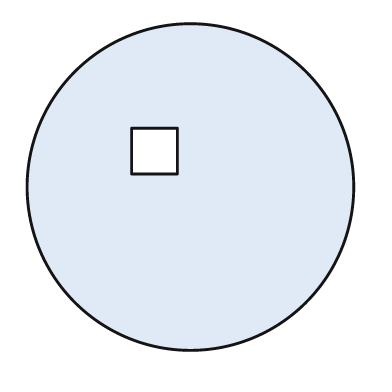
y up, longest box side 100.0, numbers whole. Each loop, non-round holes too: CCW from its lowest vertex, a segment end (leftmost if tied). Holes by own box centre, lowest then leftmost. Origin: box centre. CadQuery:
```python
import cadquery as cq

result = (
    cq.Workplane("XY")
    .moveTo(0.0, 0.0)
    .circle(50.0)
    .moveTo(-18.0, 4.0)
    .lineTo(-4.0, 4.0)
    .lineTo(-4.0, 18.0)
    .lineTo(-18.0, 18.0)
    .close()
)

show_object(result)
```